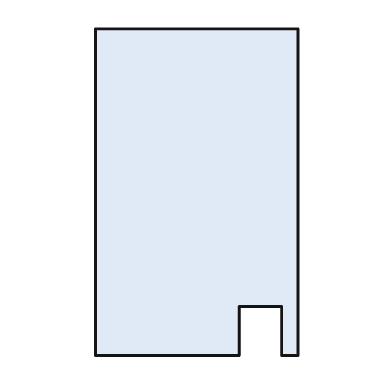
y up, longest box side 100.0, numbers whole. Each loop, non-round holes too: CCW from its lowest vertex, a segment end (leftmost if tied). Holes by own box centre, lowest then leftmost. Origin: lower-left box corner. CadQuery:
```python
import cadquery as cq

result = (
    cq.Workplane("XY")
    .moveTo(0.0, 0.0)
    .lineTo(44.0, 0.0)
    .lineTo(44.0, 15.0)
    .lineTo(57.0, 15.0)
    .lineTo(57.0, 0.0)
    .lineTo(62.0, 0.0)
    .lineTo(62.0, 100.0)
    .lineTo(0.0, 100.0)
    .close()
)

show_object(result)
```